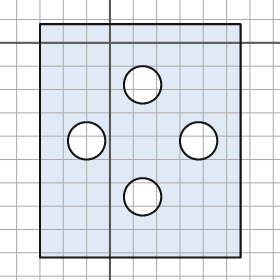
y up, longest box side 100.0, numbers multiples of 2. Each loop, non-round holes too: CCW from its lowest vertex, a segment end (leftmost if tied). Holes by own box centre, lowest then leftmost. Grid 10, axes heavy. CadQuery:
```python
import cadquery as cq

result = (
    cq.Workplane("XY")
    .moveTo(-30.0, -92.0)
    .lineTo(56.0, -92.0)
    .lineTo(56.0, 8.0)
    .lineTo(-30.0, 8.0)
    .close()
    .moveTo(14.0, -66.0)
    .circle(8.0)
    .moveTo(-10.0, -42.0)
    .circle(8.0)
    .moveTo(38.0, -42.0)
    .circle(8.0)
    .moveTo(14.0, -18.0)
    .circle(8.0)
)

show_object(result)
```